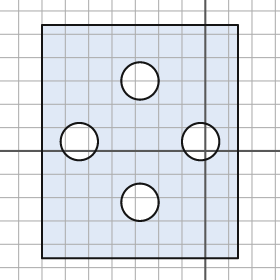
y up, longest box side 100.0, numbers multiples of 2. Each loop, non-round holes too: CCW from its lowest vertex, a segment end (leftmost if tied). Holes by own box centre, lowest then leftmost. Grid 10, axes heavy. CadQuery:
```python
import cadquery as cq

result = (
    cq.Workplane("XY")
    .moveTo(-70.0, -46.0)
    .lineTo(14.0, -46.0)
    .lineTo(14.0, 54.0)
    .lineTo(-70.0, 54.0)
    .close()
    .moveTo(-28.0, -22.0)
    .circle(8.0)
    .moveTo(-54.0, 4.0)
    .circle(8.0)
    .moveTo(-2.0, 4.0)
    .circle(8.0)
    .moveTo(-28.0, 30.0)
    .circle(8.0)
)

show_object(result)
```